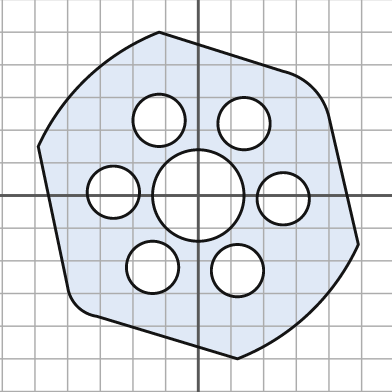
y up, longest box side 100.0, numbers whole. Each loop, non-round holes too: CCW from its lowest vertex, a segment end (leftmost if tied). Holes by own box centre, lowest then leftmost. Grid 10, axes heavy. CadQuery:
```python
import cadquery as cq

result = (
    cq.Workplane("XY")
    .moveTo(12.0, -50.0)
    .threePointArc((34.0, -36.0), (49.0, -15.0))
    .lineTo(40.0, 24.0)
    .threePointArc((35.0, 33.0), (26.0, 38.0))
    .lineTo(-12.0, 50.0)
    .threePointArc((-34.0, 36.0), (-49.0, 15.0))
    .lineTo(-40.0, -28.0)
    .threePointArc((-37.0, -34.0), (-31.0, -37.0))
    .close()
    .moveTo(12.0, -23.0)
    .circle(8.0)
    .moveTo(-14.0, -22.0)
    .circle(8.0)
    .moveTo(26.0, -1.0)
    .circle(8.0)
    .moveTo(0.0, 0.0)
    .circle(14.0)
    .moveTo(-26.0, 1.0)
    .circle(8.0)
    .moveTo(14.0, 22.0)
    .circle(8.0)
    .moveTo(-12.0, 23.0)
    .circle(8.0)
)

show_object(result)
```